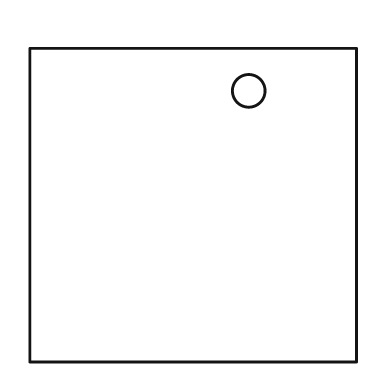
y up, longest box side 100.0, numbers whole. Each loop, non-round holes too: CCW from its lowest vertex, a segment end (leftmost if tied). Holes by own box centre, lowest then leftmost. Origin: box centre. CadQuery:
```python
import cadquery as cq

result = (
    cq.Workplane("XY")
    .moveTo(-50.0, -48.0)
    .lineTo(50.0, -48.0)
    .lineTo(50.0, 48.0)
    .lineTo(-50.0, 48.0)
    .close()
    .moveTo(17.0, 35.0)
    .circle(5.0)
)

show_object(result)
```